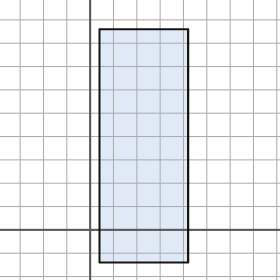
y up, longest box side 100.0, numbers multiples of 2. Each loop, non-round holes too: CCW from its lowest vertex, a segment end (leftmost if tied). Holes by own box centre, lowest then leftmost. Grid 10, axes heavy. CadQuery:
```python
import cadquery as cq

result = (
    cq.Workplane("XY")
    .moveTo(4.0, -14.0)
    .lineTo(42.0, -14.0)
    .lineTo(42.0, 86.0)
    .lineTo(4.0, 86.0)
    .close()
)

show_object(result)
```